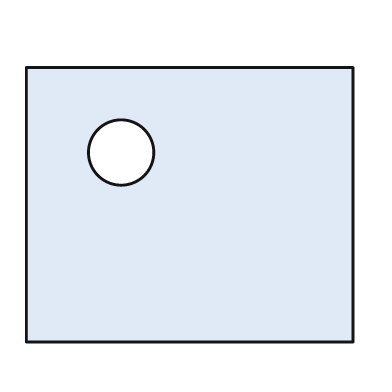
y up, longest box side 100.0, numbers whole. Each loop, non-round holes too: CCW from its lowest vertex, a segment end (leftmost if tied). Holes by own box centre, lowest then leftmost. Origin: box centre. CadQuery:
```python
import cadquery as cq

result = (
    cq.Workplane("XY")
    .moveTo(-50.0, -42.0)
    .lineTo(50.0, -42.0)
    .lineTo(50.0, 42.0)
    .lineTo(-50.0, 42.0)
    .close()
    .moveTo(-21.0, 16.0)
    .circle(10.0)
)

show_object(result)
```